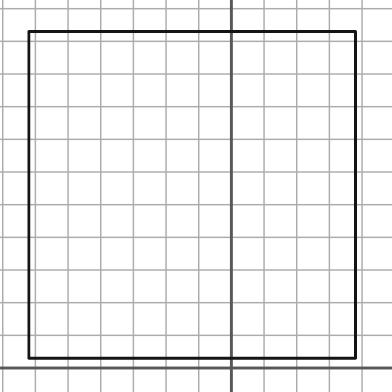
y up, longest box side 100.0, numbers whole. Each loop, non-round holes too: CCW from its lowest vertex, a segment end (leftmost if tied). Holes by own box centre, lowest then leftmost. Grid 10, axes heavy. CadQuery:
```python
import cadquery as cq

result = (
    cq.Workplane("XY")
    .moveTo(-62.0, 3.0)
    .lineTo(38.0, 3.0)
    .lineTo(38.0, 103.0)
    .lineTo(-62.0, 103.0)
    .close()
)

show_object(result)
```